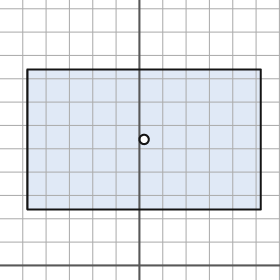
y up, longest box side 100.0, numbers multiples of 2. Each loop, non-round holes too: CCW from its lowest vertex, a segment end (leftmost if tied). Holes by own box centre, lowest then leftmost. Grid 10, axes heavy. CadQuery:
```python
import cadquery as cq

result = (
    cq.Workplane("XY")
    .moveTo(-48.0, 24.0)
    .lineTo(52.0, 24.0)
    .lineTo(52.0, 84.0)
    .lineTo(-48.0, 84.0)
    .close()
    .moveTo(2.0, 54.0)
    .circle(2.0)
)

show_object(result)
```